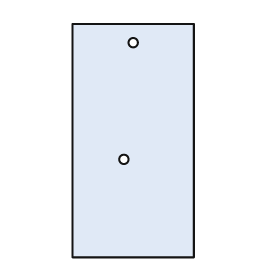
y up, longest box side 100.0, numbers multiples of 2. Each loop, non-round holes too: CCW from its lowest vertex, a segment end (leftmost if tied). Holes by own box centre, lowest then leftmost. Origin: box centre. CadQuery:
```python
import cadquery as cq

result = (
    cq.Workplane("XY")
    .moveTo(-26.0, -50.0)
    .lineTo(26.0, -50.0)
    .lineTo(26.0, 50.0)
    .lineTo(-26.0, 50.0)
    .close()
    .moveTo(-4.0, -8.0)
    .circle(2.0)
    .moveTo(0.0, 42.0)
    .circle(2.0)
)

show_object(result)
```